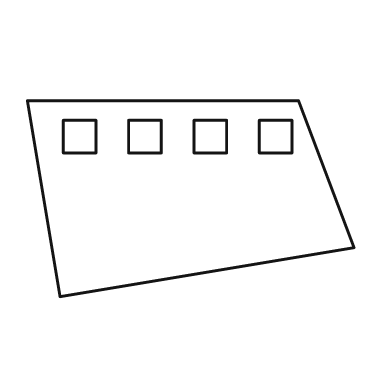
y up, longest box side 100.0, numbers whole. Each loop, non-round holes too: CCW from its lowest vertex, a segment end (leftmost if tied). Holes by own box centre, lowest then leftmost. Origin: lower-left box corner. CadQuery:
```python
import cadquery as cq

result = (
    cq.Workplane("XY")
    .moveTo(10.0, 0.0)
    .lineTo(100.0, 15.0)
    .lineTo(83.0, 60.0)
    .lineTo(0.0, 60.0)
    .close()
    .moveTo(11.0, 44.0)
    .lineTo(21.0, 44.0)
    .lineTo(21.0, 54.0)
    .lineTo(11.0, 54.0)
    .close()
    .moveTo(31.0, 44.0)
    .lineTo(41.0, 44.0)
    .lineTo(41.0, 54.0)
    .lineTo(31.0, 54.0)
    .close()
    .moveTo(51.0, 44.0)
    .lineTo(61.0, 44.0)
    .lineTo(61.0, 54.0)
    .lineTo(51.0, 54.0)
    .close()
    .moveTo(71.0, 44.0)
    .lineTo(81.0, 44.0)
    .lineTo(81.0, 54.0)
    .lineTo(71.0, 54.0)
    .close()
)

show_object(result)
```